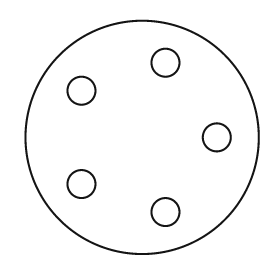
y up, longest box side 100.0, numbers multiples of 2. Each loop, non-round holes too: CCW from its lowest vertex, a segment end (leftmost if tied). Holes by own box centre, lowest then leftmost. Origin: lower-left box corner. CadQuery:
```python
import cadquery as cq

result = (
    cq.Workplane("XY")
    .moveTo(50.0, 50.0)
    .circle(50.0)
    .moveTo(60.0, 18.0)
    .circle(6.0)
    .moveTo(24.0, 30.0)
    .circle(6.0)
    .moveTo(82.0, 50.0)
    .circle(6.0)
    .moveTo(24.0, 70.0)
    .circle(6.0)
    .moveTo(60.0, 82.0)
    .circle(6.0)
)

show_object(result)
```